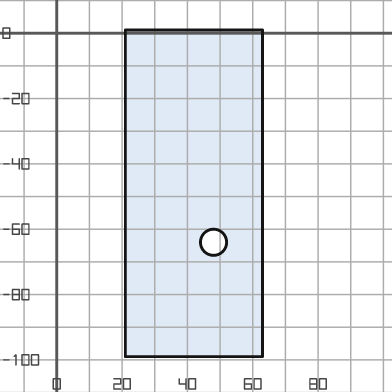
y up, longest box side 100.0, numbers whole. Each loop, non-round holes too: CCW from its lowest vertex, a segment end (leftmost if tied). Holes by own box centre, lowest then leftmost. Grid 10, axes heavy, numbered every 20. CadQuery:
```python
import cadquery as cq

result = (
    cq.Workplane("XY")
    .moveTo(21.0, -99.0)
    .lineTo(63.0, -99.0)
    .lineTo(63.0, 1.0)
    .lineTo(21.0, 1.0)
    .close()
    .moveTo(48.0, -64.0)
    .circle(4.0)
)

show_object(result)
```